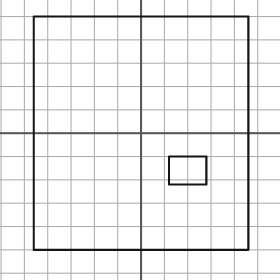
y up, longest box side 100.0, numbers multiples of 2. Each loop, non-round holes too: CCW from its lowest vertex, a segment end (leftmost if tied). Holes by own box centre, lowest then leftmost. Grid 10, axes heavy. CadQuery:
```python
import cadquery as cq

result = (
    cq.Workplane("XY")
    .moveTo(-46.0, -50.0)
    .lineTo(46.0, -50.0)
    .lineTo(46.0, 50.0)
    .lineTo(-46.0, 50.0)
    .close()
    .moveTo(12.0, -22.0)
    .lineTo(28.0, -22.0)
    .lineTo(28.0, -10.0)
    .lineTo(12.0, -10.0)
    .close()
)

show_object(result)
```